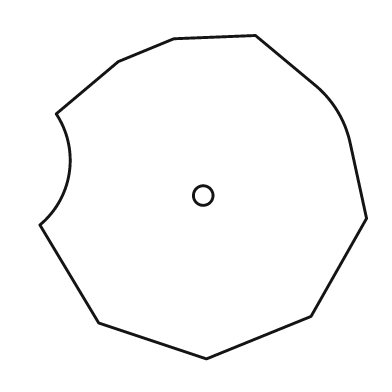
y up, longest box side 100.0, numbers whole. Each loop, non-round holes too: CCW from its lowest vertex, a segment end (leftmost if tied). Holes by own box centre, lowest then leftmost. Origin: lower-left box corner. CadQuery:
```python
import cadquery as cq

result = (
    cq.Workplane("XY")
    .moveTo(51.0, 0.0)
    .lineTo(83.0, 13.0)
    .lineTo(100.0, 43.0)
    .lineTo(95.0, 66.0)
    .threePointArc((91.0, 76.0), (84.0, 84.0))
    .lineTo(66.0, 99.0)
    .lineTo(41.0, 98.0)
    .lineTo(24.0, 91.0)
    .lineTo(5.0, 75.0)
    .threePointArc((9.0, 57.0), (0.0, 41.0))
    .lineTo(18.0, 11.0)
    .close()
    .moveTo(50.0, 50.0)
    .circle(3.0)
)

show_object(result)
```